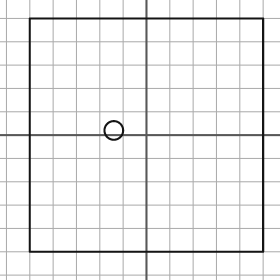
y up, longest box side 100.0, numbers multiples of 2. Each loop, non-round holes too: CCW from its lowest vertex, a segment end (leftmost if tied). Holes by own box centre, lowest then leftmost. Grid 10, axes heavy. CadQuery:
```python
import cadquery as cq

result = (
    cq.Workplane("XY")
    .moveTo(-50.0, -50.0)
    .lineTo(50.0, -50.0)
    .lineTo(50.0, 50.0)
    .lineTo(-50.0, 50.0)
    .close()
    .moveTo(-14.0, 2.0)
    .circle(4.0)
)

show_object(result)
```